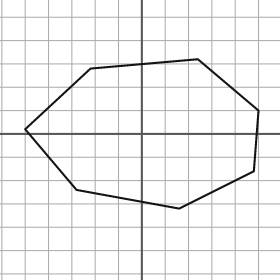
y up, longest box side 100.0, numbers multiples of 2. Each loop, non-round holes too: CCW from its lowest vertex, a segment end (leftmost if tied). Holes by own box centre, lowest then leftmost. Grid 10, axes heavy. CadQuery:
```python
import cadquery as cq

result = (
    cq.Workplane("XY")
    .moveTo(16.0, -32.0)
    .lineTo(48.0, -16.0)
    .lineTo(50.0, 10.0)
    .lineTo(24.0, 32.0)
    .lineTo(-22.0, 28.0)
    .lineTo(-50.0, 2.0)
    .lineTo(-28.0, -24.0)
    .close()
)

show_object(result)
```